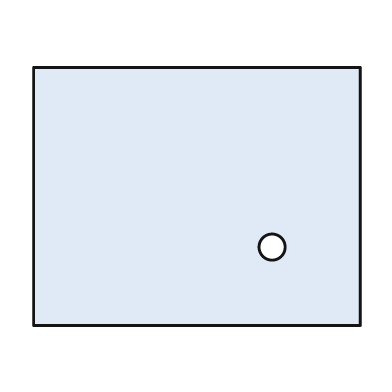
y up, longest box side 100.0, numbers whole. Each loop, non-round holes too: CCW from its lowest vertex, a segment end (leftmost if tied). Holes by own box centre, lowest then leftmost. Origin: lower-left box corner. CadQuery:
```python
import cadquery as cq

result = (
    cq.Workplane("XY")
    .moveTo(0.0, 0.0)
    .lineTo(100.0, 0.0)
    .lineTo(100.0, 79.0)
    .lineTo(0.0, 79.0)
    .close()
    .moveTo(73.0, 24.0)
    .circle(4.0)
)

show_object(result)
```